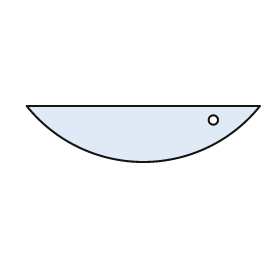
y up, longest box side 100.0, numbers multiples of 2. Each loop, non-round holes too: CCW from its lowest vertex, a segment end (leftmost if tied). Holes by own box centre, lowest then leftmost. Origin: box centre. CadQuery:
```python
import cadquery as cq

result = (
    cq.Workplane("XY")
    .moveTo(-50.0, 12.0)
    .threePointArc((0.0, -12.0), (50.0, 12.0))
    .close()
    .moveTo(30.0, 6.0)
    .circle(2.0)
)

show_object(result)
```